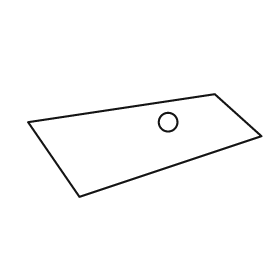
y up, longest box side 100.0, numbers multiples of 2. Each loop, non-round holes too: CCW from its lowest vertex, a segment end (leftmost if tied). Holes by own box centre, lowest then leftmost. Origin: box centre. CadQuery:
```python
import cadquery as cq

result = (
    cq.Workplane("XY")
    .moveTo(-28.0, -22.0)
    .lineTo(50.0, 4.0)
    .lineTo(30.0, 22.0)
    .lineTo(-50.0, 10.0)
    .close()
    .moveTo(10.0, 10.0)
    .circle(4.0)
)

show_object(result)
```